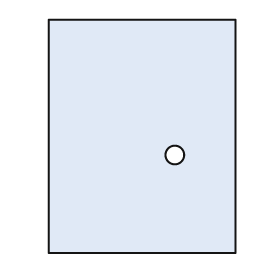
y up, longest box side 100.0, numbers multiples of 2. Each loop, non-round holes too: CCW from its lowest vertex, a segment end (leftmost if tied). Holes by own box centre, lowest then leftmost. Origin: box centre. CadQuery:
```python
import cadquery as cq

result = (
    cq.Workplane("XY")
    .moveTo(-40.0, -50.0)
    .lineTo(40.0, -50.0)
    .lineTo(40.0, 50.0)
    .lineTo(-40.0, 50.0)
    .close()
    .moveTo(14.0, -8.0)
    .circle(4.0)
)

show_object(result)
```